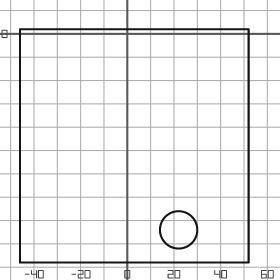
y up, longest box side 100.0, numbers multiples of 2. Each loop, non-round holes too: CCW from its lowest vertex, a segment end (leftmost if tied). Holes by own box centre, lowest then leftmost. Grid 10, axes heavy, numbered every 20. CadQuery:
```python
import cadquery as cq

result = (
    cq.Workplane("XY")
    .moveTo(-46.0, -98.0)
    .lineTo(52.0, -98.0)
    .lineTo(52.0, 2.0)
    .lineTo(-46.0, 2.0)
    .close()
    .moveTo(22.0, -84.0)
    .circle(8.0)
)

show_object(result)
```